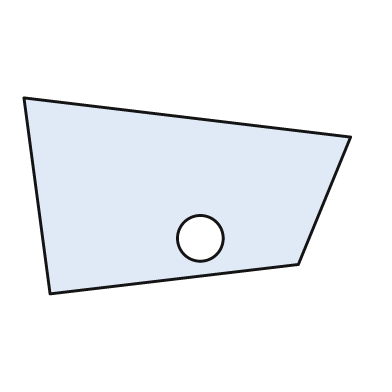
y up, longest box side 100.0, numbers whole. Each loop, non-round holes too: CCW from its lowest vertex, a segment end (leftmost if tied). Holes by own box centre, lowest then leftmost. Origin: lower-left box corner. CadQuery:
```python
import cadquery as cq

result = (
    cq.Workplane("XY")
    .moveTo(8.0, 0.0)
    .lineTo(84.0, 9.0)
    .lineTo(100.0, 48.0)
    .lineTo(0.0, 60.0)
    .close()
    .moveTo(54.0, 17.0)
    .circle(7.0)
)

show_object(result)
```